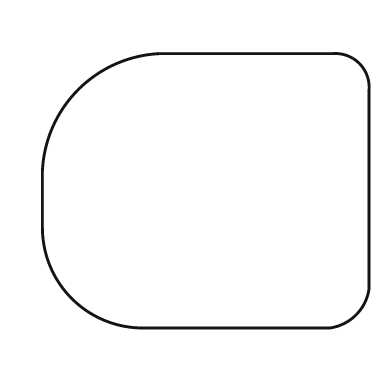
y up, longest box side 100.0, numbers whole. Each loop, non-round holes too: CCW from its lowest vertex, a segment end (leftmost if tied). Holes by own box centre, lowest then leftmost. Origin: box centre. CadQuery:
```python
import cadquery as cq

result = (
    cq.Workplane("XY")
    .moveTo(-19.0, -42.0)
    .lineTo(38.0, -42.0)
    .threePointArc((46.0, -38.0), (50.0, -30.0))
    .lineTo(50.0, 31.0)
    .threePointArc((47.0, 39.0), (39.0, 42.0))
    .lineTo(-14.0, 42.0)
    .threePointArc((-39.0, 31.0), (-50.0, 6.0))
    .lineTo(-50.0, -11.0)
    .threePointArc((-41.0, -33.0), (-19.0, -42.0))
    .close()
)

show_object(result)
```